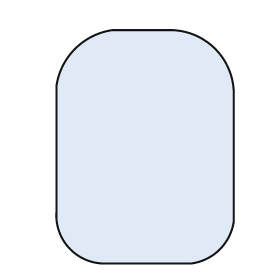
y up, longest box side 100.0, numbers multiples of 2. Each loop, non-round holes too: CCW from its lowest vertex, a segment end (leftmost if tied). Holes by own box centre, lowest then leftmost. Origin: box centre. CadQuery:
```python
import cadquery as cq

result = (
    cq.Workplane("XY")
    .moveTo(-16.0, -50.0)
    .lineTo(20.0, -50.0)
    .threePointArc((32.0, -44.0), (38.0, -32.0))
    .lineTo(38.0, 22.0)
    .threePointArc((30.0, 42.0), (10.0, 50.0))
    .lineTo(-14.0, 50.0)
    .threePointArc((-30.0, 42.0), (-38.0, 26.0))
    .lineTo(-38.0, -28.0)
    .threePointArc((-32.0, -44.0), (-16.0, -50.0))
    .close()
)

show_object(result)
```